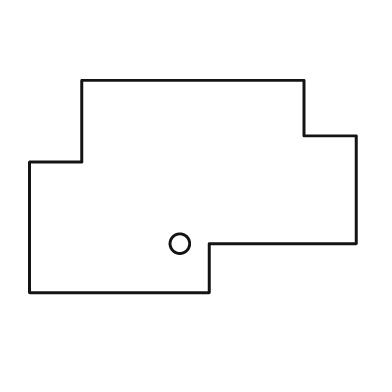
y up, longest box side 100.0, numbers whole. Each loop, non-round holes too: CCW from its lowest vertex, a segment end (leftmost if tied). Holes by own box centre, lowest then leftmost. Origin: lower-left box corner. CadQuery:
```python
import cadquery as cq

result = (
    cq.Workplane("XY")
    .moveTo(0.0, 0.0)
    .lineTo(55.0, 0.0)
    .lineTo(55.0, 15.0)
    .lineTo(100.0, 15.0)
    .lineTo(100.0, 48.0)
    .lineTo(84.0, 48.0)
    .lineTo(84.0, 65.0)
    .lineTo(16.0, 65.0)
    .lineTo(16.0, 40.0)
    .lineTo(0.0, 40.0)
    .close()
    .moveTo(46.0, 15.0)
    .circle(3.0)
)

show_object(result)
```